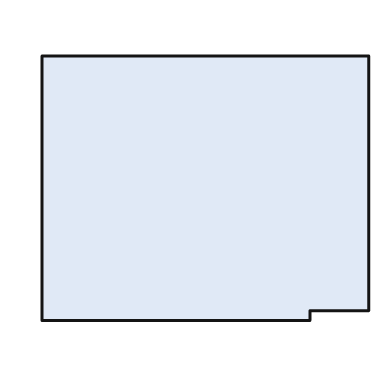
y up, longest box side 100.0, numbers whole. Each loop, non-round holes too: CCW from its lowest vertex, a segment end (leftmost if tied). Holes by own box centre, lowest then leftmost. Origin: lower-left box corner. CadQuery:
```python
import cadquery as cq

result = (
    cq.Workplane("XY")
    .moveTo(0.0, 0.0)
    .lineTo(82.0, 0.0)
    .lineTo(82.0, 3.0)
    .lineTo(100.0, 3.0)
    .lineTo(100.0, 81.0)
    .lineTo(0.0, 81.0)
    .close()
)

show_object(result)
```